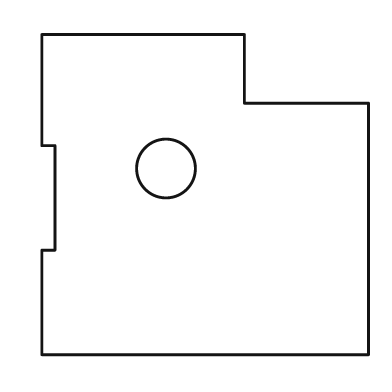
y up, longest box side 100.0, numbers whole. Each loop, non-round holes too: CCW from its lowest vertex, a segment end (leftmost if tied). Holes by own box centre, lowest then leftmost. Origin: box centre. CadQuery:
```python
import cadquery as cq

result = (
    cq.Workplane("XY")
    .moveTo(-50.0, -49.0)
    .lineTo(50.0, -49.0)
    .lineTo(50.0, 28.0)
    .lineTo(12.0, 28.0)
    .lineTo(12.0, 49.0)
    .lineTo(-50.0, 49.0)
    .lineTo(-50.0, 15.0)
    .lineTo(-46.0, 15.0)
    .lineTo(-46.0, -17.0)
    .lineTo(-50.0, -17.0)
    .close()
    .moveTo(-12.0, 8.0)
    .circle(9.0)
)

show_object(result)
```